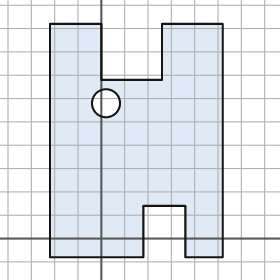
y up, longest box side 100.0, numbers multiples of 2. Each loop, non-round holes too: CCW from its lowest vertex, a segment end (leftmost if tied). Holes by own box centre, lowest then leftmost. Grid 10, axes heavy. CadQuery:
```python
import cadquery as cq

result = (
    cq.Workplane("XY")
    .moveTo(-22.0, -8.0)
    .lineTo(18.0, -8.0)
    .lineTo(18.0, 14.0)
    .lineTo(36.0, 14.0)
    .lineTo(36.0, -8.0)
    .lineTo(52.0, -8.0)
    .lineTo(52.0, 92.0)
    .lineTo(26.0, 92.0)
    .lineTo(26.0, 68.0)
    .lineTo(0.0, 68.0)
    .lineTo(0.0, 92.0)
    .lineTo(-22.0, 92.0)
    .close()
    .moveTo(2.0, 58.0)
    .circle(6.0)
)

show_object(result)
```